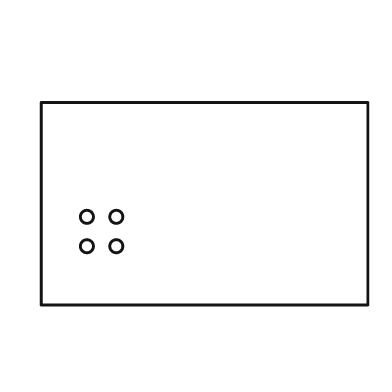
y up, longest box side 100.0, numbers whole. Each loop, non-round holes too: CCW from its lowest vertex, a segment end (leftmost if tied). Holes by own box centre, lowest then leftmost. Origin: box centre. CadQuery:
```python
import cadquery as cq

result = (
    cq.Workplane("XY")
    .moveTo(-50.0, -31.0)
    .lineTo(50.0, -31.0)
    .lineTo(50.0, 31.0)
    .lineTo(-50.0, 31.0)
    .close()
    .moveTo(-36.0, -13.0)
    .circle(2.0)
    .moveTo(-27.0, -13.0)
    .circle(2.0)
    .moveTo(-36.0, -4.0)
    .circle(2.0)
    .moveTo(-27.0, -4.0)
    .circle(2.0)
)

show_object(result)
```